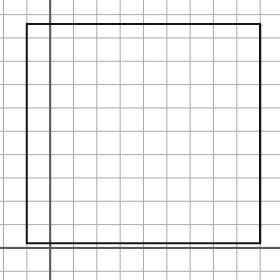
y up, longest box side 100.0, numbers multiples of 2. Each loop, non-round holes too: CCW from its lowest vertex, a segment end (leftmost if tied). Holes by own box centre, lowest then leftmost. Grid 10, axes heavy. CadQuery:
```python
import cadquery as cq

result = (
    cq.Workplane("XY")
    .moveTo(-10.0, 2.0)
    .lineTo(90.0, 2.0)
    .lineTo(90.0, 96.0)
    .lineTo(-10.0, 96.0)
    .close()
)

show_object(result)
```